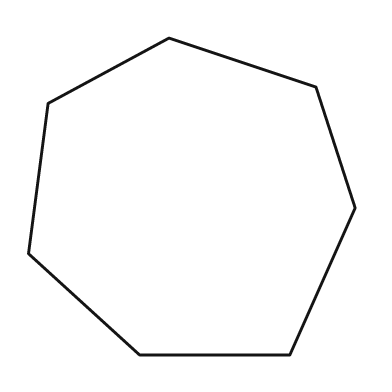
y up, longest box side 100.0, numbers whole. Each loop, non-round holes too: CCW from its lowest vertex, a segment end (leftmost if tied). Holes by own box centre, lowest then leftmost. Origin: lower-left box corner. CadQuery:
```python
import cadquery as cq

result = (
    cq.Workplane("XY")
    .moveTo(34.0, 0.0)
    .lineTo(80.0, 0.0)
    .lineTo(100.0, 45.0)
    .lineTo(88.0, 82.0)
    .lineTo(43.0, 97.0)
    .lineTo(6.0, 77.0)
    .lineTo(0.0, 31.0)
    .close()
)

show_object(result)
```